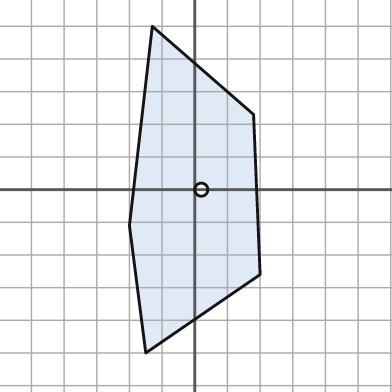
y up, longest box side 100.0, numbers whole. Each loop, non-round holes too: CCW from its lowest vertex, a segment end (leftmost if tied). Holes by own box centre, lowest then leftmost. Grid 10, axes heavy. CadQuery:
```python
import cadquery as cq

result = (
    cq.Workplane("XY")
    .moveTo(-15.0, -50.0)
    .lineTo(20.0, -26.0)
    .lineTo(18.0, 23.0)
    .lineTo(-13.0, 50.0)
    .lineTo(-20.0, -11.0)
    .close()
    .moveTo(2.0, 0.0)
    .circle(2.0)
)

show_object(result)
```